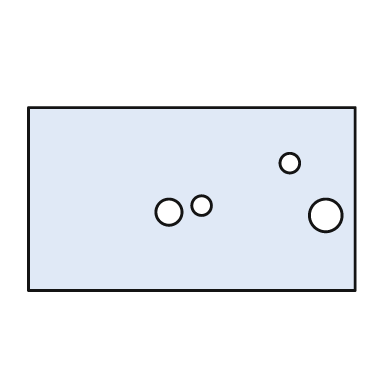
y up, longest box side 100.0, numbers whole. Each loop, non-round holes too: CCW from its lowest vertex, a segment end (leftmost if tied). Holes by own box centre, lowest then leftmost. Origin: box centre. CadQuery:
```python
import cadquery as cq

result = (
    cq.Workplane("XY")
    .moveTo(-50.0, -28.0)
    .lineTo(50.0, -28.0)
    .lineTo(50.0, 28.0)
    .lineTo(-50.0, 28.0)
    .close()
    .moveTo(41.0, -5.0)
    .circle(5.0)
    .moveTo(-7.0, -4.0)
    .circle(4.0)
    .moveTo(3.0, -2.0)
    .circle(3.0)
    .moveTo(30.0, 11.0)
    .circle(3.0)
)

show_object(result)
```